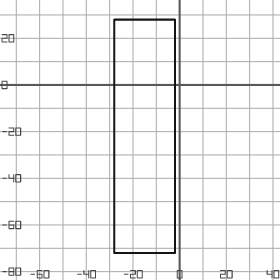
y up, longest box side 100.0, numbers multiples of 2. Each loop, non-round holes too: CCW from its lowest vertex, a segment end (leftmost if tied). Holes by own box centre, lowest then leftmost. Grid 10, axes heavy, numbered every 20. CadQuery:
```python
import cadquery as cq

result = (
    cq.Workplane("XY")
    .moveTo(-28.0, -72.0)
    .lineTo(-2.0, -72.0)
    .lineTo(-2.0, 28.0)
    .lineTo(-28.0, 28.0)
    .close()
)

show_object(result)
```